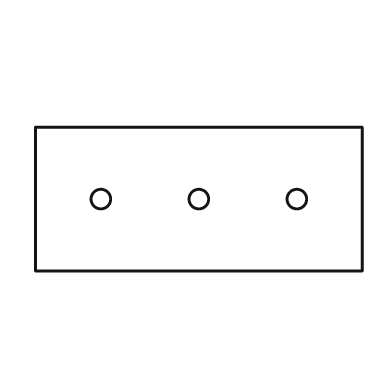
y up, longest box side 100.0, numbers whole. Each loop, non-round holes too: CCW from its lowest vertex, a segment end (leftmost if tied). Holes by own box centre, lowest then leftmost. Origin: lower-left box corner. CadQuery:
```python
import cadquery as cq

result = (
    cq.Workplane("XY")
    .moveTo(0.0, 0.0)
    .lineTo(100.0, 0.0)
    .lineTo(100.0, 44.0)
    .lineTo(0.0, 44.0)
    .close()
    .moveTo(20.0, 22.0)
    .circle(3.0)
    .moveTo(50.0, 22.0)
    .circle(3.0)
    .moveTo(80.0, 22.0)
    .circle(3.0)
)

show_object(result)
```